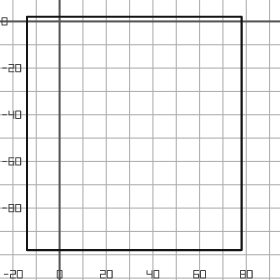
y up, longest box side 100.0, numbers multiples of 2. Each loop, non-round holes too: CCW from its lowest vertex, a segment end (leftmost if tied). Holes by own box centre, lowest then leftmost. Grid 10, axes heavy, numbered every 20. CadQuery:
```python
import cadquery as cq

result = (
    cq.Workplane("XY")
    .moveTo(-14.0, -98.0)
    .lineTo(78.0, -98.0)
    .lineTo(78.0, 2.0)
    .lineTo(-14.0, 2.0)
    .close()
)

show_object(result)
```